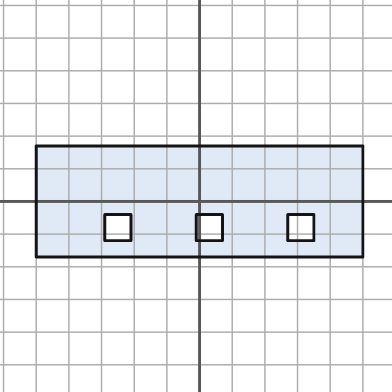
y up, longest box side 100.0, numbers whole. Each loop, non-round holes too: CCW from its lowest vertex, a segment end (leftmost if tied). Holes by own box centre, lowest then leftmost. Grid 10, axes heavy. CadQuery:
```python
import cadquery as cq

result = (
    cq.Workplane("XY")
    .moveTo(-50.0, -17.0)
    .lineTo(50.0, -17.0)
    .lineTo(50.0, 17.0)
    .lineTo(-50.0, 17.0)
    .close()
    .moveTo(-29.0, -12.0)
    .lineTo(-21.0, -12.0)
    .lineTo(-21.0, -4.0)
    .lineTo(-29.0, -4.0)
    .close()
    .moveTo(-1.0, -12.0)
    .lineTo(7.0, -12.0)
    .lineTo(7.0, -4.0)
    .lineTo(-1.0, -4.0)
    .close()
    .moveTo(27.0, -12.0)
    .lineTo(35.0, -12.0)
    .lineTo(35.0, -4.0)
    .lineTo(27.0, -4.0)
    .close()
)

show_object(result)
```